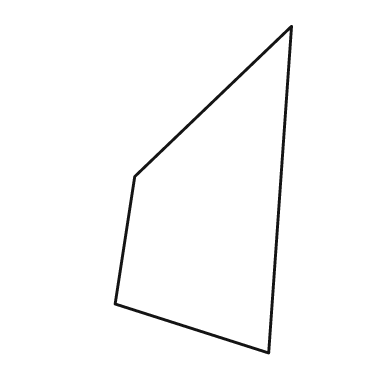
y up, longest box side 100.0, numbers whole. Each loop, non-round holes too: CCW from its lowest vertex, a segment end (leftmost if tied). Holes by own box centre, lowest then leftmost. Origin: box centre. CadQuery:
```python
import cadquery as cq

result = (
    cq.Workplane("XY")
    .moveTo(20.0, -50.0)
    .lineTo(27.0, 50.0)
    .lineTo(-21.0, 4.0)
    .lineTo(-27.0, -35.0)
    .close()
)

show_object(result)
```